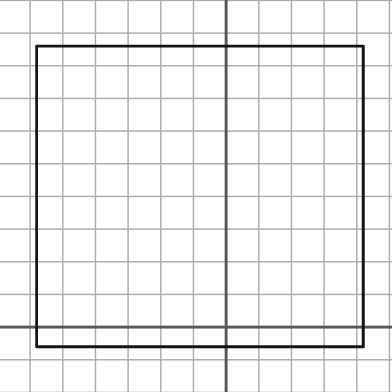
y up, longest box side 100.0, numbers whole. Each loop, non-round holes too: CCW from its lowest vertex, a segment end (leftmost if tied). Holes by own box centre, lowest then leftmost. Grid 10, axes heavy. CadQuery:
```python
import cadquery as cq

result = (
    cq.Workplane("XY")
    .moveTo(-58.0, -6.0)
    .lineTo(42.0, -6.0)
    .lineTo(42.0, 86.0)
    .lineTo(-58.0, 86.0)
    .close()
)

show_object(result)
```